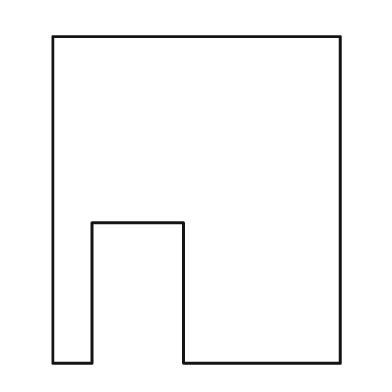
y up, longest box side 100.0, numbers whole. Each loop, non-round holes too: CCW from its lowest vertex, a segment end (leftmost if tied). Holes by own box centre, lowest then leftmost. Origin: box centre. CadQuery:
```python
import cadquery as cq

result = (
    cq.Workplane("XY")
    .moveTo(-44.0, -50.0)
    .lineTo(-32.0, -50.0)
    .lineTo(-32.0, -7.0)
    .lineTo(-4.0, -7.0)
    .lineTo(-4.0, -50.0)
    .lineTo(44.0, -50.0)
    .lineTo(44.0, 50.0)
    .lineTo(-44.0, 50.0)
    .close()
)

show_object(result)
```